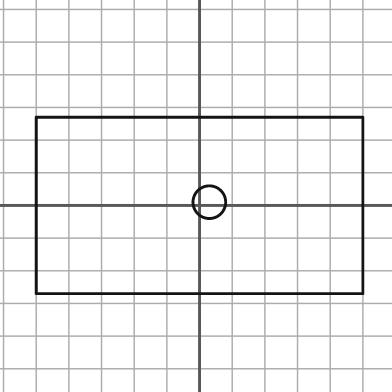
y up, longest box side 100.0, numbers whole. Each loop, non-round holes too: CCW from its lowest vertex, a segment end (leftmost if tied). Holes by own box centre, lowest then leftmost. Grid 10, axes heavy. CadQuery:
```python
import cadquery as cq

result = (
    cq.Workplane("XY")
    .moveTo(-50.0, -27.0)
    .lineTo(50.0, -27.0)
    .lineTo(50.0, 27.0)
    .lineTo(-50.0, 27.0)
    .close()
    .moveTo(3.0, 1.0)
    .circle(5.0)
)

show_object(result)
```